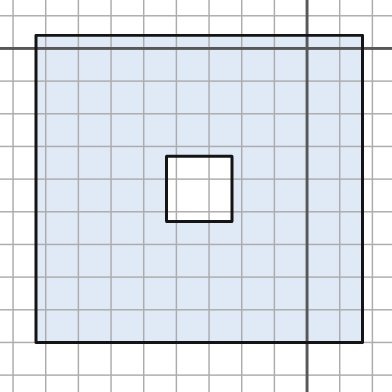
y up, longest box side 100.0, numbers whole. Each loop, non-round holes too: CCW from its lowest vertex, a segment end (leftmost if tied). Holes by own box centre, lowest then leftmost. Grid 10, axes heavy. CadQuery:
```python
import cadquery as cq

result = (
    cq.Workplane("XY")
    .moveTo(-83.0, -90.0)
    .lineTo(17.0, -90.0)
    .lineTo(17.0, 4.0)
    .lineTo(-83.0, 4.0)
    .close()
    .moveTo(-43.0, -53.0)
    .lineTo(-23.0, -53.0)
    .lineTo(-23.0, -33.0)
    .lineTo(-43.0, -33.0)
    .close()
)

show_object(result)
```